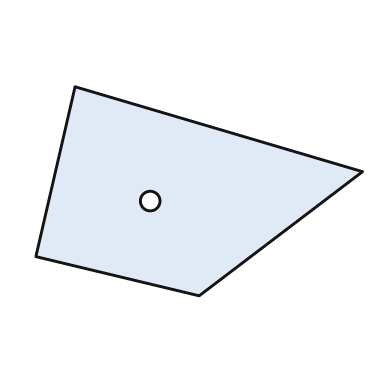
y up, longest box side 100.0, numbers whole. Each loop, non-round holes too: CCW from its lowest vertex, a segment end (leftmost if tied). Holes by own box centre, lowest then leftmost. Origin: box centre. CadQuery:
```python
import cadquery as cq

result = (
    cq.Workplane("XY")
    .moveTo(0.0, -32.0)
    .lineTo(50.0, 6.0)
    .lineTo(-38.0, 32.0)
    .lineTo(-50.0, -20.0)
    .close()
    .moveTo(-15.0, -3.0)
    .circle(3.0)
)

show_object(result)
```